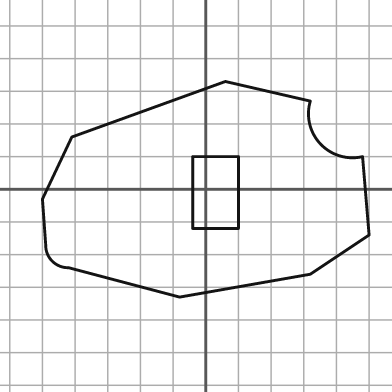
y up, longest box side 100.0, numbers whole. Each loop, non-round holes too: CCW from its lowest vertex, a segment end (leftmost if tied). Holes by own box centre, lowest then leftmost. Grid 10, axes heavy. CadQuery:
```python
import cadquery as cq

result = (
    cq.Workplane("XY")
    .moveTo(-8.0, -33.0)
    .lineTo(32.0, -26.0)
    .lineTo(50.0, -14.0)
    .lineTo(48.0, 10.0)
    .threePointArc((35.0, 14.0), (32.0, 27.0))
    .lineTo(6.0, 33.0)
    .lineTo(-41.0, 16.0)
    .lineTo(-50.0, -3.0)
    .lineTo(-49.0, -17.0)
    .threePointArc((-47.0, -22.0), (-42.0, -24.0))
    .close()
    .moveTo(-4.0, -12.0)
    .lineTo(10.0, -12.0)
    .lineTo(10.0, 10.0)
    .lineTo(-4.0, 10.0)
    .close()
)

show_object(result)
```